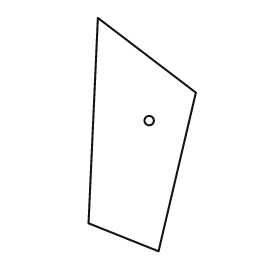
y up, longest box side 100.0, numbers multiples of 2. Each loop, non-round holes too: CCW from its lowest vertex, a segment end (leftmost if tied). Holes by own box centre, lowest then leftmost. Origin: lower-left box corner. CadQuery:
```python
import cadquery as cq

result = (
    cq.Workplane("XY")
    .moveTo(30.0, 0.0)
    .lineTo(46.0, 68.0)
    .lineTo(4.0, 100.0)
    .lineTo(0.0, 12.0)
    .close()
    .moveTo(26.0, 56.0)
    .circle(2.0)
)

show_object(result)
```